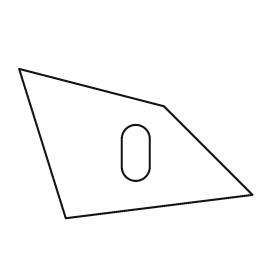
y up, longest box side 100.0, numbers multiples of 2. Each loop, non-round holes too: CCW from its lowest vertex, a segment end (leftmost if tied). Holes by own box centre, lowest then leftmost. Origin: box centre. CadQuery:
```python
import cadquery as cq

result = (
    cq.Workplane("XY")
    .moveTo(-30.0, -32.0)
    .lineTo(50.0, -22.0)
    .lineTo(12.0, 16.0)
    .lineTo(-50.0, 32.0)
    .close()
    .moveTo(-6.0, -10.0)
    .threePointArc((0.0, -16.0), (6.0, -10.0))
    .lineTo(6.0, 2.0)
    .threePointArc((0.0, 8.0), (-6.0, 2.0))
    .close()
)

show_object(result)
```